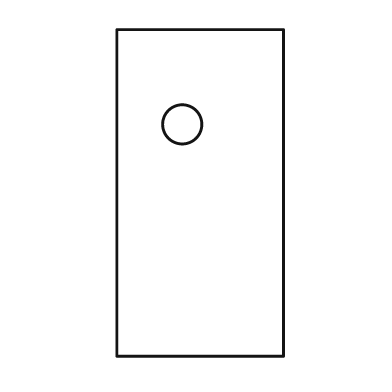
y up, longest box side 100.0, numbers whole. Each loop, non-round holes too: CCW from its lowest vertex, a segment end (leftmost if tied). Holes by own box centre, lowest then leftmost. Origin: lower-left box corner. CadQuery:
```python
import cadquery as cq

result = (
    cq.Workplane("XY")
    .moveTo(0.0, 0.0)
    .lineTo(51.0, 0.0)
    .lineTo(51.0, 100.0)
    .lineTo(0.0, 100.0)
    .close()
    .moveTo(20.0, 71.0)
    .circle(6.0)
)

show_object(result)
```